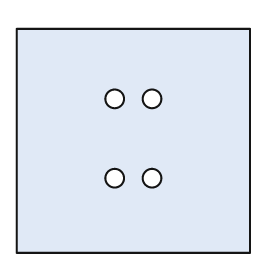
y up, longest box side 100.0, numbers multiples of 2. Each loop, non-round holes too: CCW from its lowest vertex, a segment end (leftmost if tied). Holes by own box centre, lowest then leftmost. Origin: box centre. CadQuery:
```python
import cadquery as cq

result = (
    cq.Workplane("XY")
    .moveTo(-50.0, -48.0)
    .lineTo(50.0, -48.0)
    .lineTo(50.0, 48.0)
    .lineTo(-50.0, 48.0)
    .close()
    .moveTo(-8.0, -16.0)
    .circle(4.0)
    .moveTo(8.0, -16.0)
    .circle(4.0)
    .moveTo(-8.0, 18.0)
    .circle(4.0)
    .moveTo(8.0, 18.0)
    .circle(4.0)
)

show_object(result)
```